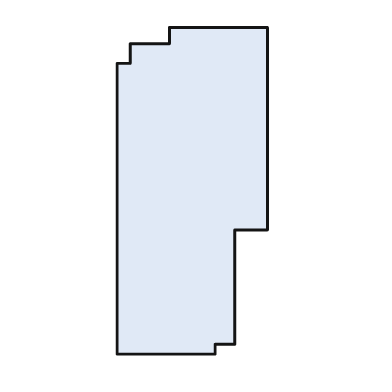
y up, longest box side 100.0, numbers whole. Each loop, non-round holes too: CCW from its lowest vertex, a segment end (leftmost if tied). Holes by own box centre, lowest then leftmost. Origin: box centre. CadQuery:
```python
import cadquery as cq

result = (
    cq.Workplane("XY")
    .moveTo(-23.0, -50.0)
    .lineTo(7.0, -50.0)
    .lineTo(7.0, -47.0)
    .lineTo(13.0, -47.0)
    .lineTo(13.0, -12.0)
    .lineTo(23.0, -12.0)
    .lineTo(23.0, 50.0)
    .lineTo(-7.0, 50.0)
    .lineTo(-7.0, 45.0)
    .lineTo(-19.0, 45.0)
    .lineTo(-19.0, 39.0)
    .lineTo(-23.0, 39.0)
    .close()
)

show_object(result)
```